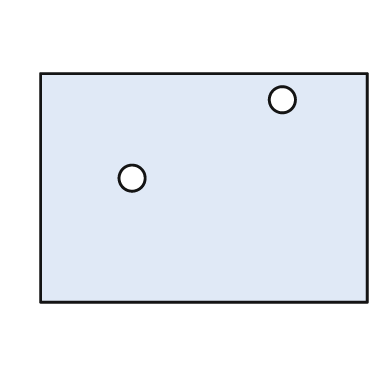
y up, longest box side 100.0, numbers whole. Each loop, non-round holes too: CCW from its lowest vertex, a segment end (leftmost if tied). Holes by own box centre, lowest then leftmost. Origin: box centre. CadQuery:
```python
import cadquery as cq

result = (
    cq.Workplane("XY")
    .moveTo(-50.0, -35.0)
    .lineTo(50.0, -35.0)
    .lineTo(50.0, 35.0)
    .lineTo(-50.0, 35.0)
    .close()
    .moveTo(-22.0, 3.0)
    .circle(4.0)
    .moveTo(24.0, 27.0)
    .circle(4.0)
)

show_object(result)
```